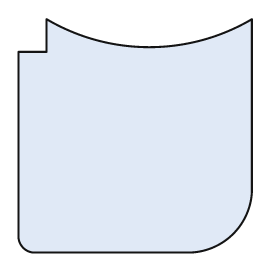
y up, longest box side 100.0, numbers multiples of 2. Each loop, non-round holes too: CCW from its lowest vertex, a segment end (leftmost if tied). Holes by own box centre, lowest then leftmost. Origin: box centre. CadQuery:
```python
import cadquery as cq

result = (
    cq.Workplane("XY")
    .moveTo(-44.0, -50.0)
    .lineTo(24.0, -50.0)
    .threePointArc((42.0, -42.0), (50.0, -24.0))
    .lineTo(50.0, 50.0)
    .threePointArc((6.0, 38.0), (-38.0, 50.0))
    .lineTo(-38.0, 36.0)
    .lineTo(-50.0, 36.0)
    .lineTo(-50.0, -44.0)
    .threePointArc((-48.0, -48.0), (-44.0, -50.0))
    .close()
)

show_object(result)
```